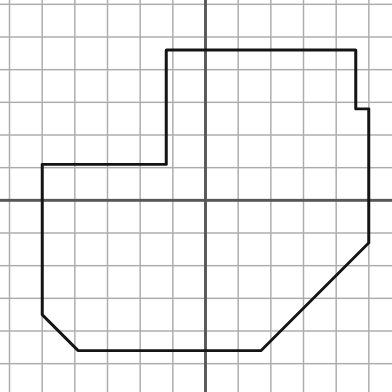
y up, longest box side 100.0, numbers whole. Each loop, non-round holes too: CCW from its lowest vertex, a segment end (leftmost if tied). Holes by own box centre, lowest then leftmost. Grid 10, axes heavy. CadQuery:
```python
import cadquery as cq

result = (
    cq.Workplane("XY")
    .moveTo(-39.0, -46.0)
    .lineTo(17.0, -46.0)
    .lineTo(50.0, -13.0)
    .lineTo(50.0, 28.0)
    .lineTo(46.0, 28.0)
    .lineTo(46.0, 46.0)
    .lineTo(-12.0, 46.0)
    .lineTo(-12.0, 11.0)
    .lineTo(-50.0, 11.0)
    .lineTo(-50.0, -35.0)
    .close()
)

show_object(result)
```